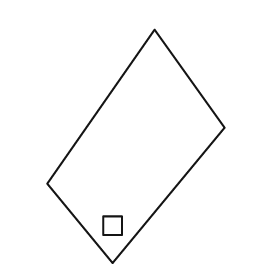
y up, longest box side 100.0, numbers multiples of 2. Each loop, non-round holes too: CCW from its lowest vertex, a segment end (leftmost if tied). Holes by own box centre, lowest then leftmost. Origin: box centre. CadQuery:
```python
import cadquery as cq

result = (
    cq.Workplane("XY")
    .moveTo(-10.0, -50.0)
    .lineTo(38.0, 8.0)
    .lineTo(8.0, 50.0)
    .lineTo(-38.0, -16.0)
    .close()
    .moveTo(-14.0, -38.0)
    .lineTo(-6.0, -38.0)
    .lineTo(-6.0, -30.0)
    .lineTo(-14.0, -30.0)
    .close()
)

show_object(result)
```